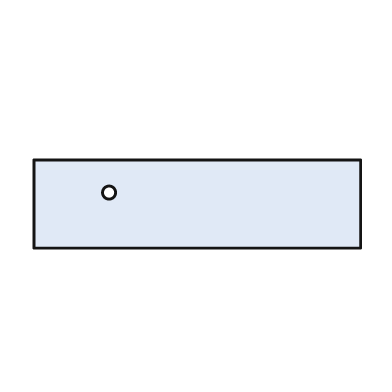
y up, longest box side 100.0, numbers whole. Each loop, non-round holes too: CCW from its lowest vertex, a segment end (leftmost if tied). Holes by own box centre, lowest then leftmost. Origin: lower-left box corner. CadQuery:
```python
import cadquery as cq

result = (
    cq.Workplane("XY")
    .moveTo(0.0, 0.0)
    .lineTo(100.0, 0.0)
    .lineTo(100.0, 27.0)
    .lineTo(0.0, 27.0)
    .close()
    .moveTo(23.0, 17.0)
    .circle(2.0)
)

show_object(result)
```